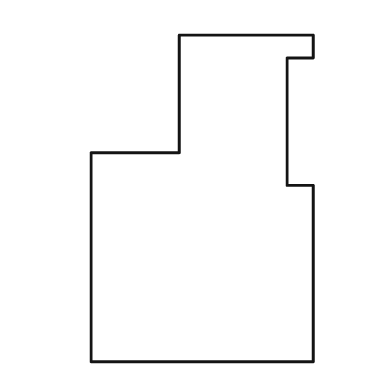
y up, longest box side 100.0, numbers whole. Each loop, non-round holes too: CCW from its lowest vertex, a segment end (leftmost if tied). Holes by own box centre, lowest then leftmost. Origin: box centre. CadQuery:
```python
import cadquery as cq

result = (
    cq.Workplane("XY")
    .moveTo(-34.0, -50.0)
    .lineTo(34.0, -50.0)
    .lineTo(34.0, 4.0)
    .lineTo(26.0, 4.0)
    .lineTo(26.0, 43.0)
    .lineTo(34.0, 43.0)
    .lineTo(34.0, 50.0)
    .lineTo(-7.0, 50.0)
    .lineTo(-7.0, 14.0)
    .lineTo(-34.0, 14.0)
    .close()
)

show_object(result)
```